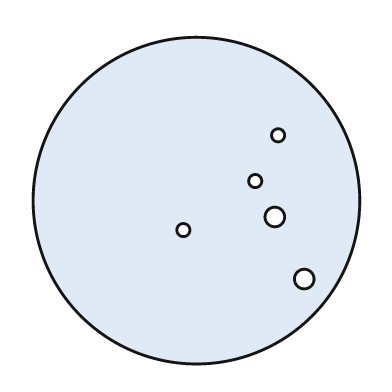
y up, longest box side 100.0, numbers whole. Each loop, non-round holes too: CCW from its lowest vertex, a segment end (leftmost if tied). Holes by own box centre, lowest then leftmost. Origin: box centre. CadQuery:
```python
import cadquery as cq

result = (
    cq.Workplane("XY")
    .moveTo(0.0, 0.0)
    .circle(50.0)
    .moveTo(33.0, -24.0)
    .circle(3.0)
    .moveTo(-4.0, -9.0)
    .circle(2.0)
    .moveTo(24.0, -5.0)
    .circle(3.0)
    .moveTo(18.0, 6.0)
    .circle(2.0)
    .moveTo(25.0, 20.0)
    .circle(2.0)
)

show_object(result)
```